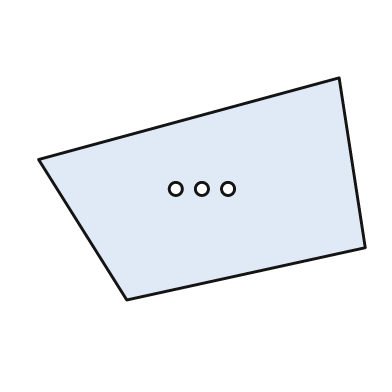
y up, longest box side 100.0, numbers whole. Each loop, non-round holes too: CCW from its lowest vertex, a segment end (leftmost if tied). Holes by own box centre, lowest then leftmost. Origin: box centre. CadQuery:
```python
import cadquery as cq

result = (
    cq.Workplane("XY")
    .moveTo(-23.0, -34.0)
    .lineTo(50.0, -18.0)
    .lineTo(42.0, 34.0)
    .lineTo(-50.0, 9.0)
    .close()
    .moveTo(-8.0, 0.0)
    .circle(2.0)
    .moveTo(0.0, 0.0)
    .circle(2.0)
    .moveTo(8.0, 0.0)
    .circle(2.0)
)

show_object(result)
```